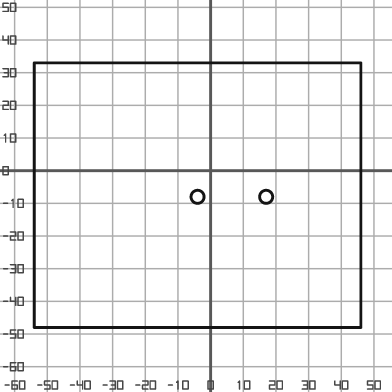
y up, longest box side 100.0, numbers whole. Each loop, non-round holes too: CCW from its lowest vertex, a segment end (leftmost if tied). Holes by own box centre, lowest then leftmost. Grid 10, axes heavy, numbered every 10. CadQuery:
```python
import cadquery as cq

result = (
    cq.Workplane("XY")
    .moveTo(-54.0, -48.0)
    .lineTo(46.0, -48.0)
    .lineTo(46.0, 33.0)
    .lineTo(-54.0, 33.0)
    .close()
    .moveTo(-4.0, -8.0)
    .circle(2.0)
    .moveTo(17.0, -8.0)
    .circle(2.0)
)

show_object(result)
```